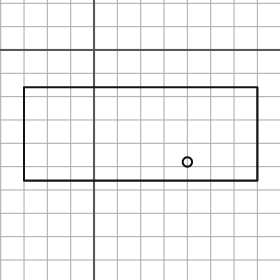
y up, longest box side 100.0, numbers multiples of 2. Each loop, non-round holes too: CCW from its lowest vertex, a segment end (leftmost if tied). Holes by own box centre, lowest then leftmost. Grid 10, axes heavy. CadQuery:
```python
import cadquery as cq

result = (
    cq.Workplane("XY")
    .moveTo(-30.0, -56.0)
    .lineTo(70.0, -56.0)
    .lineTo(70.0, -16.0)
    .lineTo(-30.0, -16.0)
    .close()
    .moveTo(40.0, -48.0)
    .circle(2.0)
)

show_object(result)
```